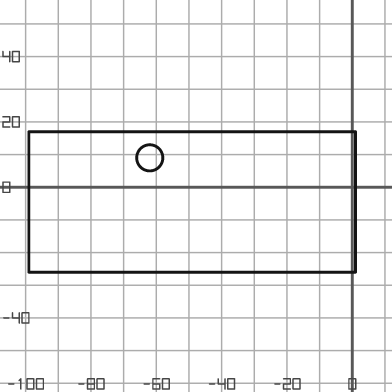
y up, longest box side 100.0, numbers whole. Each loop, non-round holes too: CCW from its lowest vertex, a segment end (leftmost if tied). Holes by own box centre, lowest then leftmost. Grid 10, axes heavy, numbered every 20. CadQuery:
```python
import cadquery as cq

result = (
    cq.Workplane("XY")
    .moveTo(-99.0, -26.0)
    .lineTo(1.0, -26.0)
    .lineTo(1.0, 17.0)
    .lineTo(-99.0, 17.0)
    .close()
    .moveTo(-62.0, 9.0)
    .circle(4.0)
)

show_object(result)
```